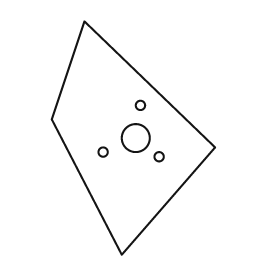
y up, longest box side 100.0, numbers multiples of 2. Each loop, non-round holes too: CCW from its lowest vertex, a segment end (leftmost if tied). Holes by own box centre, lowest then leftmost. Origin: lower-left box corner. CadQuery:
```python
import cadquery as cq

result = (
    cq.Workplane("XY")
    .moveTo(30.0, 0.0)
    .lineTo(70.0, 46.0)
    .lineTo(14.0, 100.0)
    .lineTo(0.0, 58.0)
    .close()
    .moveTo(46.0, 42.0)
    .circle(2.0)
    .moveTo(22.0, 44.0)
    .circle(2.0)
    .moveTo(36.0, 50.0)
    .circle(6.0)
    .moveTo(38.0, 64.0)
    .circle(2.0)
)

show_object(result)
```